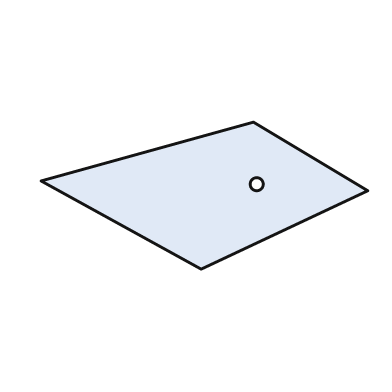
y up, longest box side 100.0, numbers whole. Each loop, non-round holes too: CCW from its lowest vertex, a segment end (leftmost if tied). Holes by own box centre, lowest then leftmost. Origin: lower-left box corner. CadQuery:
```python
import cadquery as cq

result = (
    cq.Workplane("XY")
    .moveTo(49.0, 0.0)
    .lineTo(100.0, 24.0)
    .lineTo(65.0, 45.0)
    .lineTo(0.0, 27.0)
    .close()
    .moveTo(66.0, 26.0)
    .circle(2.0)
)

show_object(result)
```